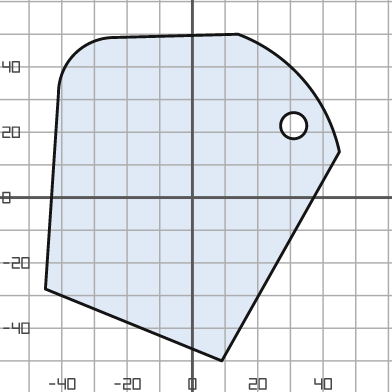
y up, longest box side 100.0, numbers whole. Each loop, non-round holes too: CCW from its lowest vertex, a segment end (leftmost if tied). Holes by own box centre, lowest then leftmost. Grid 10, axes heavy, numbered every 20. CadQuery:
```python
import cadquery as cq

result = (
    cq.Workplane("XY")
    .moveTo(9.0, -50.0)
    .lineTo(45.0, 14.0)
    .threePointArc((34.0, 36.0), (14.0, 50.0))
    .lineTo(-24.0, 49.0)
    .threePointArc((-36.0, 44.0), (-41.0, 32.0))
    .lineTo(-45.0, -28.0)
    .close()
    .moveTo(31.0, 22.0)
    .circle(4.0)
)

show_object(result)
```